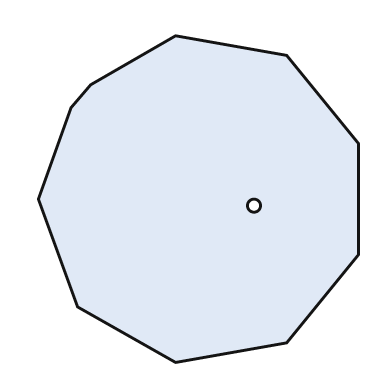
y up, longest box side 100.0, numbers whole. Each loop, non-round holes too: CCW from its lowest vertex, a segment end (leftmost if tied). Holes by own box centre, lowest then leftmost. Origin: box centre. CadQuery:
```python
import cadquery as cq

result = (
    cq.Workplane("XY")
    .moveTo(-7.0, -50.0)
    .lineTo(27.0, -44.0)
    .lineTo(49.0, -17.0)
    .lineTo(49.0, 17.0)
    .lineTo(27.0, 44.0)
    .lineTo(-7.0, 50.0)
    .lineTo(-33.0, 35.0)
    .lineTo(-39.0, 28.0)
    .lineTo(-49.0, 0.0)
    .lineTo(-37.0, -33.0)
    .close()
    .moveTo(17.0, -2.0)
    .circle(2.0)
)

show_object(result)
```